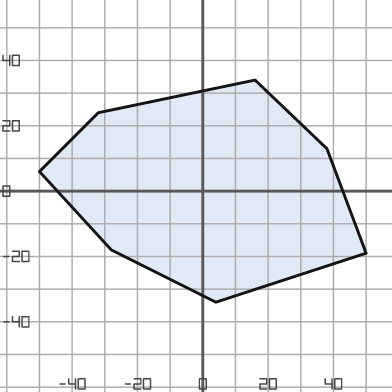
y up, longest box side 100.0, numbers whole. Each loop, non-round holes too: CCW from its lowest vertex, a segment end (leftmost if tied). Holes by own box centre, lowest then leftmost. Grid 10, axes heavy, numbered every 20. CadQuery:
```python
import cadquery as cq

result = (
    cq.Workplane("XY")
    .moveTo(4.0, -34.0)
    .lineTo(50.0, -19.0)
    .lineTo(38.0, 13.0)
    .lineTo(16.0, 34.0)
    .lineTo(-32.0, 24.0)
    .lineTo(-50.0, 6.0)
    .lineTo(-28.0, -18.0)
    .close()
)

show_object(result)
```